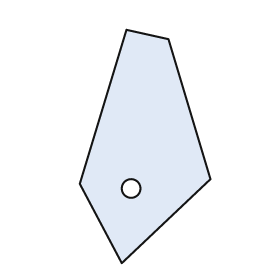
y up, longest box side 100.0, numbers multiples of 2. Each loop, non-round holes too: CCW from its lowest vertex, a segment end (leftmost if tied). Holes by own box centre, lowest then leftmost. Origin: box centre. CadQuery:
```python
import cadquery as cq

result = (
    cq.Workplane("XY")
    .moveTo(-10.0, -50.0)
    .lineTo(28.0, -14.0)
    .lineTo(10.0, 46.0)
    .lineTo(-8.0, 50.0)
    .lineTo(-28.0, -16.0)
    .close()
    .moveTo(-6.0, -18.0)
    .circle(4.0)
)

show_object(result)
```